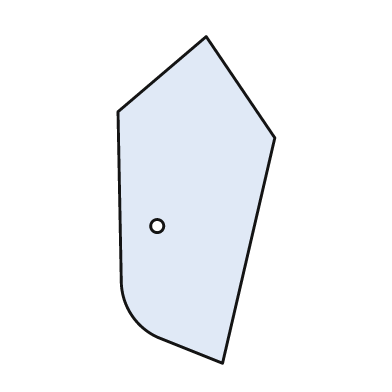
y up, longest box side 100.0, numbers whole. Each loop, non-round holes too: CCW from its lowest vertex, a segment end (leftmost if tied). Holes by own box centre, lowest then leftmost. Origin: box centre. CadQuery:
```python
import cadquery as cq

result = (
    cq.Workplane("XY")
    .moveTo(8.0, -50.0)
    .lineTo(24.0, 19.0)
    .lineTo(3.0, 50.0)
    .lineTo(-24.0, 27.0)
    .lineTo(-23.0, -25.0)
    .threePointArc((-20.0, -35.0), (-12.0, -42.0))
    .close()
    .moveTo(-12.0, -8.0)
    .circle(2.0)
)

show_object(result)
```